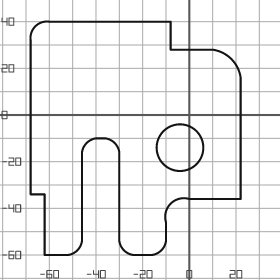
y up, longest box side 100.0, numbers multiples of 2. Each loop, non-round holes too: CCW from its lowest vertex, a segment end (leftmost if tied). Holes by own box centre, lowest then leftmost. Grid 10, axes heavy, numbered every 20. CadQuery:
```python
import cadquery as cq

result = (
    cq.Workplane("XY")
    .moveTo(-62.0, -60.0)
    .lineTo(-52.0, -60.0)
    .threePointArc((-48.0, -58.0), (-46.0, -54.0))
    .lineTo(-46.0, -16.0)
    .threePointArc((-44.0, -12.0), (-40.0, -10.0))
    .lineTo(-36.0, -10.0)
    .threePointArc((-32.0, -12.0), (-30.0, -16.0))
    .lineTo(-30.0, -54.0)
    .threePointArc((-28.0, -58.0), (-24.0, -60.0))
    .lineTo(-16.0, -60.0)
    .threePointArc((-12.0, -58.0), (-10.0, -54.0))
    .lineTo(-10.0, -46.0)
    .threePointArc((-8.0, -38.0), (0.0, -36.0))
    .lineTo(22.0, -36.0)
    .lineTo(22.0, 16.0)
    .threePointArc((18.0, 24.0), (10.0, 28.0))
    .lineTo(-8.0, 28.0)
    .lineTo(-8.0, 40.0)
    .lineTo(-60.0, 40.0)
    .threePointArc((-66.0, 38.0), (-68.0, 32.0))
    .lineTo(-68.0, -34.0)
    .lineTo(-62.0, -34.0)
    .close()
    .moveTo(-4.0, -14.0)
    .circle(10.0)
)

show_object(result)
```